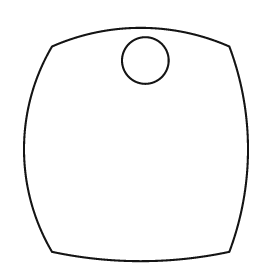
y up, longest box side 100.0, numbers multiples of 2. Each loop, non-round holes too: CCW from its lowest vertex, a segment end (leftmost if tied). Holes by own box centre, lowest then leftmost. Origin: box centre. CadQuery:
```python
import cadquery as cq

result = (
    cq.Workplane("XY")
    .moveTo(-36.0, -46.0)
    .threePointArc((2.0, -50.0), (40.0, -46.0))
    .threePointArc((48.0, -2.0), (40.0, 42.0))
    .threePointArc((2.0, 50.0), (-36.0, 42.0))
    .threePointArc((-48.0, -2.0), (-36.0, -46.0))
    .close()
    .moveTo(4.0, 36.0)
    .circle(10.0)
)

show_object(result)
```